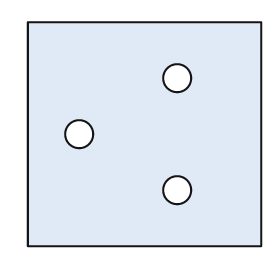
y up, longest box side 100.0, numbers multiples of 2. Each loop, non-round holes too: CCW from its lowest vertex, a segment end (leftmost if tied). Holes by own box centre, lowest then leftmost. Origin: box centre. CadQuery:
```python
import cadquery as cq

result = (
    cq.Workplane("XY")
    .moveTo(-50.0, -48.0)
    .lineTo(50.0, -48.0)
    .lineTo(50.0, 48.0)
    .lineTo(-50.0, 48.0)
    .close()
    .moveTo(14.0, -24.0)
    .circle(6.0)
    .moveTo(-28.0, 0.0)
    .circle(6.0)
    .moveTo(14.0, 24.0)
    .circle(6.0)
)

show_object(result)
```